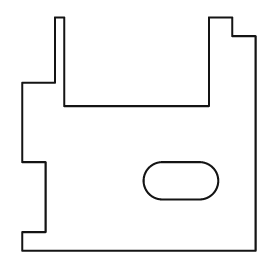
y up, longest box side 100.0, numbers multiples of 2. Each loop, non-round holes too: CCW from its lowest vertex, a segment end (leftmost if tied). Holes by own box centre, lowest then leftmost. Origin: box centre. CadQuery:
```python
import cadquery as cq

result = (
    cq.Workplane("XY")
    .moveTo(-50.0, -50.0)
    .lineTo(50.0, -50.0)
    .lineTo(50.0, 42.0)
    .lineTo(40.0, 42.0)
    .lineTo(40.0, 50.0)
    .lineTo(30.0, 50.0)
    .lineTo(30.0, 12.0)
    .lineTo(-32.0, 12.0)
    .lineTo(-32.0, 50.0)
    .lineTo(-36.0, 50.0)
    .lineTo(-36.0, 22.0)
    .lineTo(-50.0, 22.0)
    .lineTo(-50.0, -12.0)
    .lineTo(-40.0, -12.0)
    .lineTo(-40.0, -42.0)
    .lineTo(-50.0, -42.0)
    .close()
    .moveTo(10.0, -28.0)
    .lineTo(26.0, -28.0)
    .threePointArc((34.0, -20.0), (26.0, -12.0))
    .lineTo(10.0, -12.0)
    .threePointArc((2.0, -20.0), (10.0, -28.0))
    .close()
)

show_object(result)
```